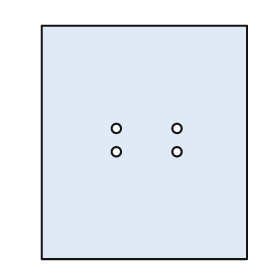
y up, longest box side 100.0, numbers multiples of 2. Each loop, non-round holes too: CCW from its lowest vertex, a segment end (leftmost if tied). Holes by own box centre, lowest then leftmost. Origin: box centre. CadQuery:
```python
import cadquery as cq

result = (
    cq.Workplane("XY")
    .moveTo(-44.0, -50.0)
    .lineTo(44.0, -50.0)
    .lineTo(44.0, 50.0)
    .lineTo(-44.0, 50.0)
    .close()
    .moveTo(-12.0, -4.0)
    .circle(2.0)
    .moveTo(14.0, -4.0)
    .circle(2.0)
    .moveTo(-12.0, 6.0)
    .circle(2.0)
    .moveTo(14.0, 6.0)
    .circle(2.0)
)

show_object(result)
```